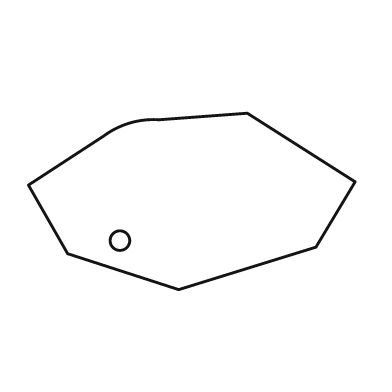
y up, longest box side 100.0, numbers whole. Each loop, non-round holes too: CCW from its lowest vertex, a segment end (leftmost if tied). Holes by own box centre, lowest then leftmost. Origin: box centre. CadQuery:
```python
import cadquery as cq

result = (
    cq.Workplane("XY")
    .moveTo(-4.0, -27.0)
    .lineTo(38.0, -14.0)
    .lineTo(50.0, 6.0)
    .lineTo(17.0, 27.0)
    .lineTo(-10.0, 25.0)
    .threePointArc((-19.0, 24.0), (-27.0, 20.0))
    .lineTo(-50.0, 5.0)
    .lineTo(-38.0, -16.0)
    .close()
    .moveTo(-22.0, -12.0)
    .circle(3.0)
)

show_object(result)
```